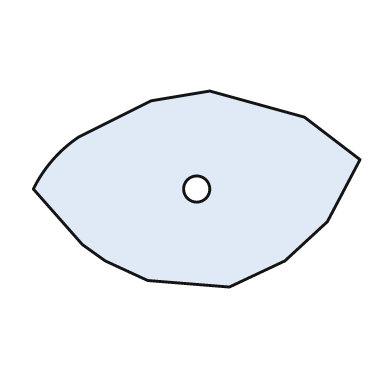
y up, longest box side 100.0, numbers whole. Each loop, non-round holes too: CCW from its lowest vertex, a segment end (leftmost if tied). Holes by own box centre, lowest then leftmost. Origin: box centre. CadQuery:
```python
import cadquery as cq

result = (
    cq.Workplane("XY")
    .moveTo(10.0, -30.0)
    .lineTo(27.0, -22.0)
    .lineTo(40.0, -10.0)
    .lineTo(50.0, 9.0)
    .lineTo(33.0, 22.0)
    .lineTo(4.0, 30.0)
    .lineTo(-14.0, 27.0)
    .lineTo(-36.0, 16.0)
    .threePointArc((-44.0, 9.0), (-50.0, 0.0))
    .lineTo(-35.0, -17.0)
    .lineTo(-28.0, -22.0)
    .lineTo(-15.0, -28.0)
    .close()
    .moveTo(0.0, 0.0)
    .circle(4.0)
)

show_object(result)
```